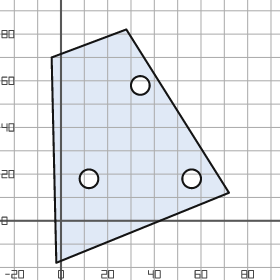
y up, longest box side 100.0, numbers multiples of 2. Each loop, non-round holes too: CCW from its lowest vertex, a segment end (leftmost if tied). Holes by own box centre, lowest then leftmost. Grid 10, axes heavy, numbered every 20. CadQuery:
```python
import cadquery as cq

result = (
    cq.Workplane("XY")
    .moveTo(-2.0, -18.0)
    .lineTo(72.0, 12.0)
    .lineTo(28.0, 82.0)
    .lineTo(-4.0, 70.0)
    .close()
    .moveTo(12.0, 18.0)
    .circle(4.0)
    .moveTo(56.0, 18.0)
    .circle(4.0)
    .moveTo(34.0, 58.0)
    .circle(4.0)
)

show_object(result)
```